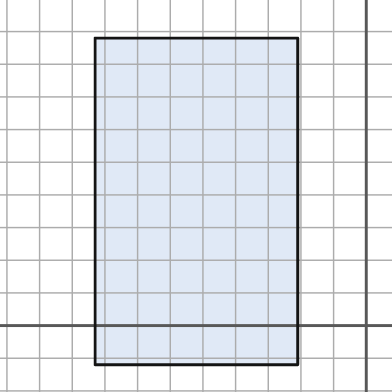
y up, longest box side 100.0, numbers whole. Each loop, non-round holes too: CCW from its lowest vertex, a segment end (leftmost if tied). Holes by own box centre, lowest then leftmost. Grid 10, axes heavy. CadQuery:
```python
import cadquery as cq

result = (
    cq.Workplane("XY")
    .moveTo(-83.0, -12.0)
    .lineTo(-21.0, -12.0)
    .lineTo(-21.0, 88.0)
    .lineTo(-83.0, 88.0)
    .close()
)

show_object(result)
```